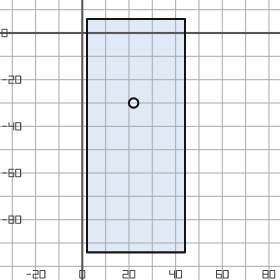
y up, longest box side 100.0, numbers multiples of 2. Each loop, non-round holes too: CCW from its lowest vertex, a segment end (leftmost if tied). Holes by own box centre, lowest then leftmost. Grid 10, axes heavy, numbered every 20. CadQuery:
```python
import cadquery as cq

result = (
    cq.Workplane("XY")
    .moveTo(2.0, -94.0)
    .lineTo(44.0, -94.0)
    .lineTo(44.0, 6.0)
    .lineTo(2.0, 6.0)
    .close()
    .moveTo(22.0, -30.0)
    .circle(2.0)
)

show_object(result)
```